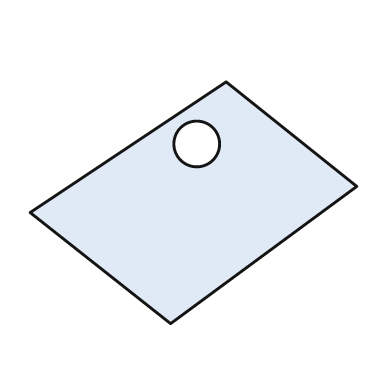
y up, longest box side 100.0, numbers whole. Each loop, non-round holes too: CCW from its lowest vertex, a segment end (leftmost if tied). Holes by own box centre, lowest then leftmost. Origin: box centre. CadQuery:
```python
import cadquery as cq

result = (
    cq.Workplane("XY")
    .moveTo(-7.0, -37.0)
    .lineTo(50.0, 5.0)
    .lineTo(10.0, 37.0)
    .lineTo(-50.0, -3.0)
    .close()
    .moveTo(1.0, 18.0)
    .circle(7.0)
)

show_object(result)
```